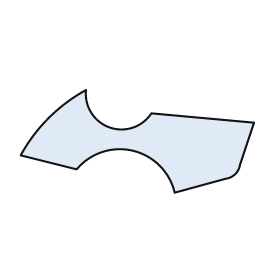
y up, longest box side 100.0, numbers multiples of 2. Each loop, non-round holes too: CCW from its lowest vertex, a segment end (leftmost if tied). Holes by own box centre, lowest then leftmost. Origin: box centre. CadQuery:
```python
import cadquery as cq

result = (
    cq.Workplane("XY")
    .moveTo(16.0, -22.0)
    .lineTo(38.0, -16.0)
    .threePointArc((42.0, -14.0), (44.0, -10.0))
    .lineTo(50.0, 8.0)
    .lineTo(6.0, 12.0)
    .threePointArc((-12.0, 6.0), (-22.0, 22.0))
    .threePointArc((-38.0, 10.0), (-50.0, -6.0))
    .lineTo(-26.0, -12.0)
    .threePointArc((-2.0, -4.0), (16.0, -22.0))
    .close()
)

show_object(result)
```